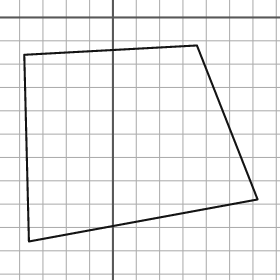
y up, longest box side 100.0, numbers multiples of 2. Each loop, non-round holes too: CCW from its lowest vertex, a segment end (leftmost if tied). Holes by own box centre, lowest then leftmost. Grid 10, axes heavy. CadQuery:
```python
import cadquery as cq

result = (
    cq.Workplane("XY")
    .moveTo(-36.0, -96.0)
    .lineTo(62.0, -78.0)
    .lineTo(36.0, -12.0)
    .lineTo(-38.0, -16.0)
    .close()
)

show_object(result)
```